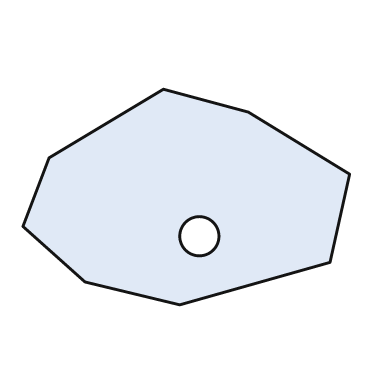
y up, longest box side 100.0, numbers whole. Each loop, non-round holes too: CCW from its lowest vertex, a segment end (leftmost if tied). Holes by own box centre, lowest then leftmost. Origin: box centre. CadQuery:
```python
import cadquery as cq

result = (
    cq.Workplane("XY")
    .moveTo(-2.0, -33.0)
    .lineTo(44.0, -20.0)
    .lineTo(50.0, 7.0)
    .lineTo(19.0, 26.0)
    .lineTo(-7.0, 33.0)
    .lineTo(-42.0, 12.0)
    .lineTo(-50.0, -9.0)
    .lineTo(-31.0, -26.0)
    .close()
    .moveTo(4.0, -12.0)
    .circle(6.0)
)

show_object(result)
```